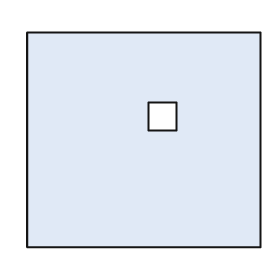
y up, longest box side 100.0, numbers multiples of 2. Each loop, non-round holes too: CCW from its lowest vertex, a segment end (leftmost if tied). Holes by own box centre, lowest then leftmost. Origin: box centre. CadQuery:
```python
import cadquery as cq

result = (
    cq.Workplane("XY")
    .moveTo(-50.0, -46.0)
    .lineTo(50.0, -46.0)
    .lineTo(50.0, 46.0)
    .lineTo(-50.0, 46.0)
    .close()
    .moveTo(2.0, 4.0)
    .lineTo(14.0, 4.0)
    .lineTo(14.0, 16.0)
    .lineTo(2.0, 16.0)
    .close()
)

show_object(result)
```